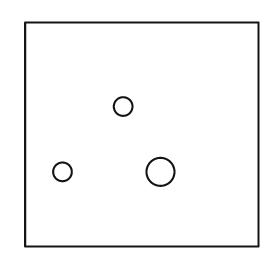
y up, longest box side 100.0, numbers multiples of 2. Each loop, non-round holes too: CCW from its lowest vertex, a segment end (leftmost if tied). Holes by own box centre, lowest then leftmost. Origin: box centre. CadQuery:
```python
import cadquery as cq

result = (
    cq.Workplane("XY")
    .moveTo(-50.0, -48.0)
    .lineTo(50.0, -48.0)
    .lineTo(50.0, 48.0)
    .lineTo(-50.0, 48.0)
    .close()
    .moveTo(-34.0, -16.0)
    .circle(4.0)
    .moveTo(8.0, -16.0)
    .circle(6.0)
    .moveTo(-8.0, 12.0)
    .circle(4.0)
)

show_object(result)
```